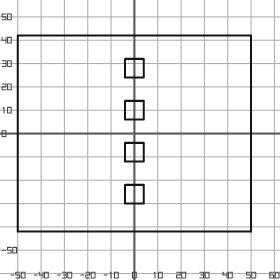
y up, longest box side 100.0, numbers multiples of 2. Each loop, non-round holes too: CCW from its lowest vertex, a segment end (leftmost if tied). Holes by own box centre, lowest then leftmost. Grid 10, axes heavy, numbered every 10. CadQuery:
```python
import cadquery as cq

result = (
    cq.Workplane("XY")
    .moveTo(-50.0, -42.0)
    .lineTo(50.0, -42.0)
    .lineTo(50.0, 42.0)
    .lineTo(-50.0, 42.0)
    .close()
    .moveTo(-4.0, -30.0)
    .lineTo(4.0, -30.0)
    .lineTo(4.0, -22.0)
    .lineTo(-4.0, -22.0)
    .close()
    .moveTo(-4.0, -12.0)
    .lineTo(4.0, -12.0)
    .lineTo(4.0, -4.0)
    .lineTo(-4.0, -4.0)
    .close()
    .moveTo(-4.0, 6.0)
    .lineTo(4.0, 6.0)
    .lineTo(4.0, 14.0)
    .lineTo(-4.0, 14.0)
    .close()
    .moveTo(-4.0, 24.0)
    .lineTo(4.0, 24.0)
    .lineTo(4.0, 32.0)
    .lineTo(-4.0, 32.0)
    .close()
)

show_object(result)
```